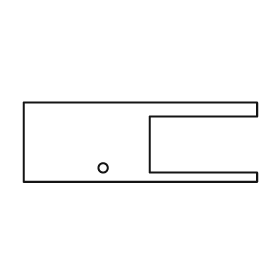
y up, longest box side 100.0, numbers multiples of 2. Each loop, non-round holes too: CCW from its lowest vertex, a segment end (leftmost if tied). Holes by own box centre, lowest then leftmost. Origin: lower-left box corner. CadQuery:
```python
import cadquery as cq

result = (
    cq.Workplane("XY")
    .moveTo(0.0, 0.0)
    .lineTo(100.0, 0.0)
    .lineTo(100.0, 4.0)
    .lineTo(54.0, 4.0)
    .lineTo(54.0, 28.0)
    .lineTo(100.0, 28.0)
    .lineTo(100.0, 34.0)
    .lineTo(0.0, 34.0)
    .close()
    .moveTo(34.0, 6.0)
    .circle(2.0)
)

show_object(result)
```